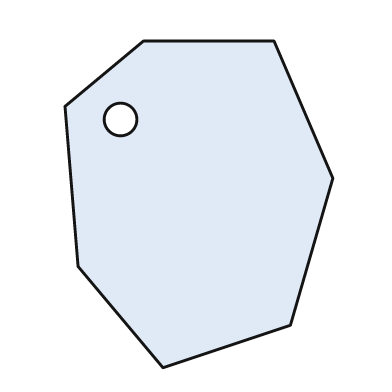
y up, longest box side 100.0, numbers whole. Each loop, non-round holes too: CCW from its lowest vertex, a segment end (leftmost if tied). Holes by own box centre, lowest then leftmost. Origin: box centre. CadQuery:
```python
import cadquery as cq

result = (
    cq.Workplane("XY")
    .moveTo(-11.0, -50.0)
    .lineTo(28.0, -37.0)
    .lineTo(41.0, 8.0)
    .lineTo(23.0, 50.0)
    .lineTo(-17.0, 50.0)
    .lineTo(-41.0, 30.0)
    .lineTo(-37.0, -19.0)
    .close()
    .moveTo(-24.0, 26.0)
    .circle(5.0)
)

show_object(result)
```